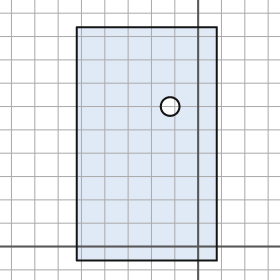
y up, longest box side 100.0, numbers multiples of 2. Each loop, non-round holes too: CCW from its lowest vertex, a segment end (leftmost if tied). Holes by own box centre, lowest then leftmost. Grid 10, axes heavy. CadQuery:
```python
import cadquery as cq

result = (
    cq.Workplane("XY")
    .moveTo(-52.0, -6.0)
    .lineTo(8.0, -6.0)
    .lineTo(8.0, 94.0)
    .lineTo(-52.0, 94.0)
    .close()
    .moveTo(-12.0, 60.0)
    .circle(4.0)
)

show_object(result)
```